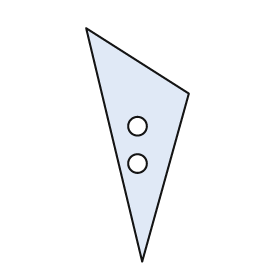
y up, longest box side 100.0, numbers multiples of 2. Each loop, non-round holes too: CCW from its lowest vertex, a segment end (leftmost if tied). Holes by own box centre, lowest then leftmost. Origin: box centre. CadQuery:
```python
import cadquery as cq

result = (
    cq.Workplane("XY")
    .moveTo(2.0, -50.0)
    .lineTo(22.0, 22.0)
    .lineTo(-22.0, 50.0)
    .close()
    .moveTo(0.0, -8.0)
    .circle(4.0)
    .moveTo(0.0, 8.0)
    .circle(4.0)
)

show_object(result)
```